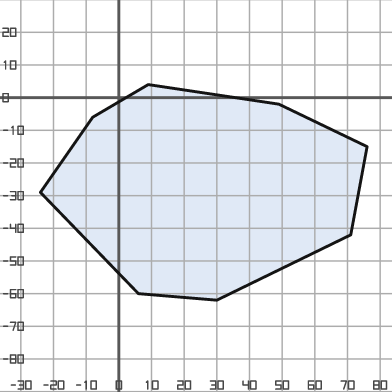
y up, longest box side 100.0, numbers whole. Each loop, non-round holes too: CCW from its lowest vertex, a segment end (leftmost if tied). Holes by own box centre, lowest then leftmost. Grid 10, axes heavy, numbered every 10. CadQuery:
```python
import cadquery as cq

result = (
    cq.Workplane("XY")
    .moveTo(30.0, -62.0)
    .lineTo(71.0, -42.0)
    .lineTo(76.0, -15.0)
    .lineTo(49.0, -2.0)
    .lineTo(9.0, 4.0)
    .lineTo(-8.0, -6.0)
    .lineTo(-24.0, -29.0)
    .lineTo(6.0, -60.0)
    .close()
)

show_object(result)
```